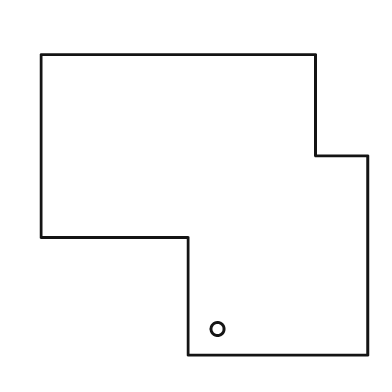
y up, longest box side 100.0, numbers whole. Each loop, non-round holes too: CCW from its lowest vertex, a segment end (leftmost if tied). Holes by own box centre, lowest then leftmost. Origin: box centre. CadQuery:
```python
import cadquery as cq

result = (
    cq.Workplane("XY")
    .moveTo(-5.0, -46.0)
    .lineTo(50.0, -46.0)
    .lineTo(50.0, 15.0)
    .lineTo(34.0, 15.0)
    .lineTo(34.0, 46.0)
    .lineTo(-50.0, 46.0)
    .lineTo(-50.0, -10.0)
    .lineTo(-5.0, -10.0)
    .close()
    .moveTo(4.0, -38.0)
    .circle(2.0)
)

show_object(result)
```